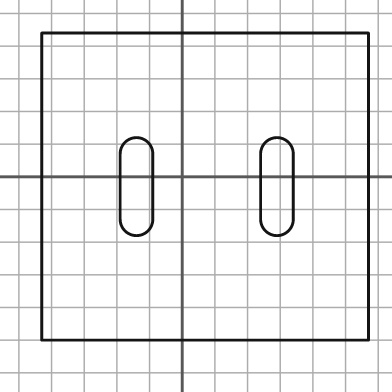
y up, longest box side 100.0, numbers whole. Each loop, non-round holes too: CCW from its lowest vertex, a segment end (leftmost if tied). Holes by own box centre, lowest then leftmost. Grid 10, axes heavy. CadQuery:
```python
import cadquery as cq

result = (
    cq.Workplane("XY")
    .moveTo(-43.0, -50.0)
    .lineTo(57.0, -50.0)
    .lineTo(57.0, 44.0)
    .lineTo(-43.0, 44.0)
    .close()
    .moveTo(-19.0, -13.0)
    .threePointArc((-14.0, -18.0), (-9.0, -13.0))
    .lineTo(-9.0, 7.0)
    .threePointArc((-14.0, 12.0), (-19.0, 7.0))
    .close()
    .moveTo(24.0, -13.0)
    .threePointArc((29.0, -18.0), (34.0, -13.0))
    .lineTo(34.0, 7.0)
    .threePointArc((29.0, 12.0), (24.0, 7.0))
    .close()
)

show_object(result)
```